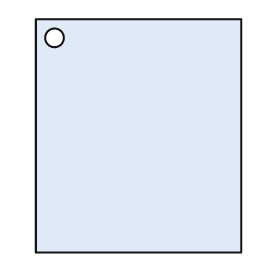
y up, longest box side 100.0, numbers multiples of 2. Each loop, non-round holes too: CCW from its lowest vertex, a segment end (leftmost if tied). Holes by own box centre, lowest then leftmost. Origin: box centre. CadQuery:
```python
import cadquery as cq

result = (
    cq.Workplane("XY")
    .moveTo(-44.0, -50.0)
    .lineTo(44.0, -50.0)
    .lineTo(44.0, 50.0)
    .lineTo(-44.0, 50.0)
    .close()
    .moveTo(-36.0, 42.0)
    .circle(4.0)
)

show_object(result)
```